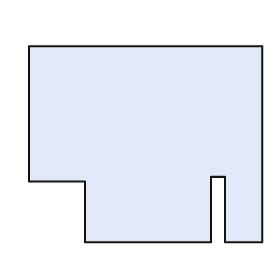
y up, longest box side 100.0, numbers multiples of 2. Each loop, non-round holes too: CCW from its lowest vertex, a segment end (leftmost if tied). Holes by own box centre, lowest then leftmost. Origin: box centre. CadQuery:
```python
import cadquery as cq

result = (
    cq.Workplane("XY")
    .moveTo(-26.0, -42.0)
    .lineTo(28.0, -42.0)
    .lineTo(28.0, -14.0)
    .lineTo(34.0, -14.0)
    .lineTo(34.0, -42.0)
    .lineTo(50.0, -42.0)
    .lineTo(50.0, 42.0)
    .lineTo(-50.0, 42.0)
    .lineTo(-50.0, -16.0)
    .lineTo(-26.0, -16.0)
    .close()
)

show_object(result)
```